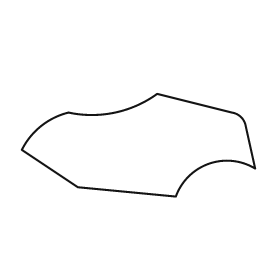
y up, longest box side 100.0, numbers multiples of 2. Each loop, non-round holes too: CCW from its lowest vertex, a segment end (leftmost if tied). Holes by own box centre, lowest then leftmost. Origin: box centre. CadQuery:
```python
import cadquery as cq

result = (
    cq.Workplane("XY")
    .moveTo(16.0, -22.0)
    .threePointArc((30.0, -8.0), (50.0, -10.0))
    .lineTo(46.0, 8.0)
    .threePointArc((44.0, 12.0), (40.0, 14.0))
    .lineTo(8.0, 22.0)
    .threePointArc((-10.0, 14.0), (-30.0, 14.0))
    .threePointArc((-42.0, 8.0), (-50.0, -2.0))
    .lineTo(-26.0, -18.0)
    .close()
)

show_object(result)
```